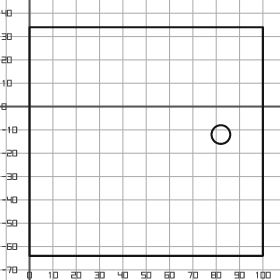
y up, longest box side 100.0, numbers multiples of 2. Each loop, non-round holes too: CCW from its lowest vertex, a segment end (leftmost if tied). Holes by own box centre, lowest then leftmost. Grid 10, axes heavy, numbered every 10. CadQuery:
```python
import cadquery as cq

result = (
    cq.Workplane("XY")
    .moveTo(0.0, -64.0)
    .lineTo(100.0, -64.0)
    .lineTo(100.0, 34.0)
    .lineTo(0.0, 34.0)
    .close()
    .moveTo(82.0, -12.0)
    .circle(4.0)
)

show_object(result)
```